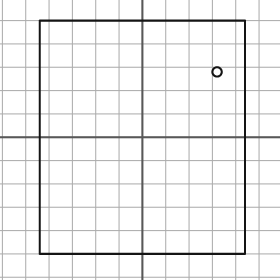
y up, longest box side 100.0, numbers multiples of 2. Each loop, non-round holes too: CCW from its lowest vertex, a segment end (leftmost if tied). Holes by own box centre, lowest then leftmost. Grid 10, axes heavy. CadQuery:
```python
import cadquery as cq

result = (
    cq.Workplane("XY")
    .moveTo(-44.0, -50.0)
    .lineTo(44.0, -50.0)
    .lineTo(44.0, 50.0)
    .lineTo(-44.0, 50.0)
    .close()
    .moveTo(32.0, 28.0)
    .circle(2.0)
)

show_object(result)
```